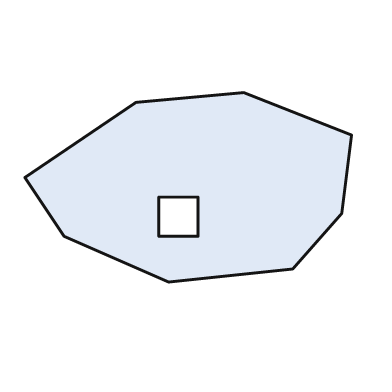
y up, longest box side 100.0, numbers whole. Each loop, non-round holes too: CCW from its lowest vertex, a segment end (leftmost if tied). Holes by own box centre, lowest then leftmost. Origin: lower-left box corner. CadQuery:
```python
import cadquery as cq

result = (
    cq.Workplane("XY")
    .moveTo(44.0, 0.0)
    .lineTo(82.0, 4.0)
    .lineTo(97.0, 21.0)
    .lineTo(100.0, 45.0)
    .lineTo(67.0, 58.0)
    .lineTo(34.0, 55.0)
    .lineTo(0.0, 32.0)
    .lineTo(12.0, 14.0)
    .close()
    .moveTo(41.0, 14.0)
    .lineTo(53.0, 14.0)
    .lineTo(53.0, 26.0)
    .lineTo(41.0, 26.0)
    .close()
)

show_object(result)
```